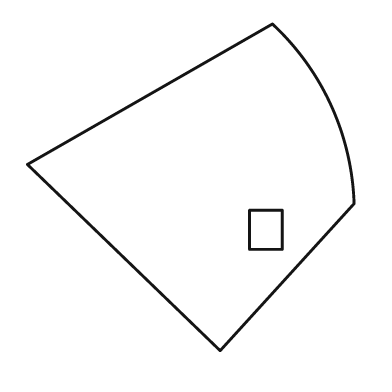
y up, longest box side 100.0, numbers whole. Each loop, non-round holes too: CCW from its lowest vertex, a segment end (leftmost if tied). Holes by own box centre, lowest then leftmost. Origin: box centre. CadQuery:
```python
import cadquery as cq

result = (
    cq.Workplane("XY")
    .moveTo(9.0, -50.0)
    .lineTo(50.0, -5.0)
    .threePointArc((43.0, 25.0), (25.0, 50.0))
    .lineTo(-50.0, 7.0)
    .close()
    .moveTo(18.0, -19.0)
    .lineTo(28.0, -19.0)
    .lineTo(28.0, -7.0)
    .lineTo(18.0, -7.0)
    .close()
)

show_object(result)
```